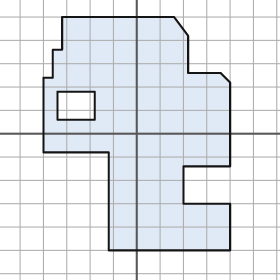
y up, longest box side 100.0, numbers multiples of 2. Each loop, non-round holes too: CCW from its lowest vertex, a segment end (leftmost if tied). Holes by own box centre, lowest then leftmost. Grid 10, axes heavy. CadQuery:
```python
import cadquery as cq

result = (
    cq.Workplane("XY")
    .moveTo(-12.0, -50.0)
    .lineTo(40.0, -50.0)
    .lineTo(40.0, -30.0)
    .lineTo(20.0, -30.0)
    .lineTo(20.0, -14.0)
    .lineTo(40.0, -14.0)
    .lineTo(40.0, 22.0)
    .lineTo(36.0, 26.0)
    .lineTo(22.0, 26.0)
    .lineTo(22.0, 42.0)
    .lineTo(16.0, 50.0)
    .lineTo(-32.0, 50.0)
    .lineTo(-32.0, 36.0)
    .lineTo(-36.0, 36.0)
    .lineTo(-36.0, 24.0)
    .lineTo(-40.0, 24.0)
    .lineTo(-40.0, -8.0)
    .lineTo(-12.0, -8.0)
    .close()
    .moveTo(-34.0, 6.0)
    .lineTo(-18.0, 6.0)
    .lineTo(-18.0, 18.0)
    .lineTo(-34.0, 18.0)
    .close()
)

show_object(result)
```